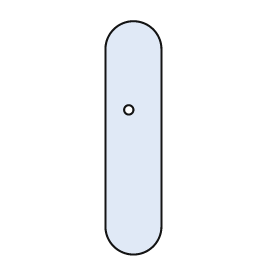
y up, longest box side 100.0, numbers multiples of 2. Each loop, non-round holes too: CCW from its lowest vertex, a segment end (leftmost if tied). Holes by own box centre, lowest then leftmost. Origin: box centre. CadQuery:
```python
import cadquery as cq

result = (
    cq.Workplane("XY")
    .moveTo(-12.0, -38.0)
    .threePointArc((0.0, -50.0), (12.0, -38.0))
    .lineTo(12.0, 38.0)
    .threePointArc((0.0, 50.0), (-12.0, 38.0))
    .close()
    .moveTo(-2.0, 12.0)
    .circle(2.0)
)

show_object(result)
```